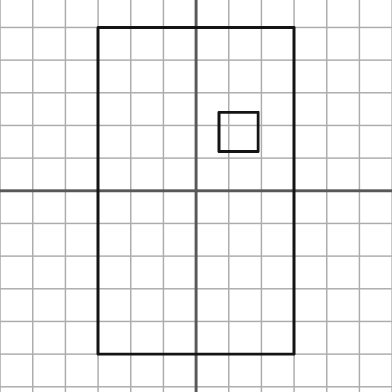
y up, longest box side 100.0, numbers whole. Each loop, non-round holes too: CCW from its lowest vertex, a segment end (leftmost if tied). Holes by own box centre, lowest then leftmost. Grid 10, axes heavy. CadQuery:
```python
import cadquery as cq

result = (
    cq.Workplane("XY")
    .moveTo(-30.0, -50.0)
    .lineTo(30.0, -50.0)
    .lineTo(30.0, 50.0)
    .lineTo(-30.0, 50.0)
    .close()
    .moveTo(7.0, 12.0)
    .lineTo(19.0, 12.0)
    .lineTo(19.0, 24.0)
    .lineTo(7.0, 24.0)
    .close()
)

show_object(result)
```